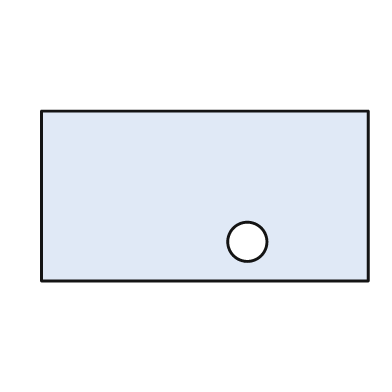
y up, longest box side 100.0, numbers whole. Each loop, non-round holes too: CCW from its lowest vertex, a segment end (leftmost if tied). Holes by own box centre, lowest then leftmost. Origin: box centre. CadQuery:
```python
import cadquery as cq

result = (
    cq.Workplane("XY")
    .moveTo(-50.0, -26.0)
    .lineTo(50.0, -26.0)
    .lineTo(50.0, 26.0)
    .lineTo(-50.0, 26.0)
    .close()
    .moveTo(13.0, -14.0)
    .circle(6.0)
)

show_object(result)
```